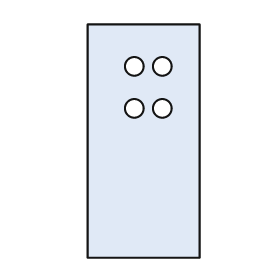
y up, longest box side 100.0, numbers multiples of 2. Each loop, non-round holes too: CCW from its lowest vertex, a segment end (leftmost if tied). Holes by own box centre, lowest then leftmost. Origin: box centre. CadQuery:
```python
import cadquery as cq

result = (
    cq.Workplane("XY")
    .moveTo(-24.0, -50.0)
    .lineTo(24.0, -50.0)
    .lineTo(24.0, 50.0)
    .lineTo(-24.0, 50.0)
    .close()
    .moveTo(-4.0, 14.0)
    .circle(4.0)
    .moveTo(8.0, 14.0)
    .circle(4.0)
    .moveTo(-4.0, 32.0)
    .circle(4.0)
    .moveTo(8.0, 32.0)
    .circle(4.0)
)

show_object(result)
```